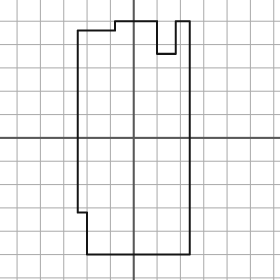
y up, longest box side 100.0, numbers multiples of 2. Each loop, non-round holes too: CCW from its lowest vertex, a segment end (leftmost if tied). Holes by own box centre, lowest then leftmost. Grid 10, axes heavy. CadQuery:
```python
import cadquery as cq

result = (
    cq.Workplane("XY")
    .moveTo(-20.0, -50.0)
    .lineTo(24.0, -50.0)
    .lineTo(24.0, 50.0)
    .lineTo(18.0, 50.0)
    .lineTo(18.0, 36.0)
    .lineTo(10.0, 36.0)
    .lineTo(10.0, 50.0)
    .lineTo(-8.0, 50.0)
    .lineTo(-8.0, 46.0)
    .lineTo(-24.0, 46.0)
    .lineTo(-24.0, -32.0)
    .lineTo(-20.0, -32.0)
    .close()
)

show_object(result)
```